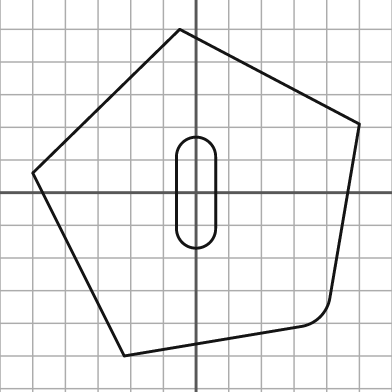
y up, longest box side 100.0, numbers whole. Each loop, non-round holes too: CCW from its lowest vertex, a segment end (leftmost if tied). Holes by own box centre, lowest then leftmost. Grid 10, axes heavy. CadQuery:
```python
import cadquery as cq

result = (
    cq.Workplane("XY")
    .moveTo(-22.0, -50.0)
    .lineTo(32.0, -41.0)
    .threePointArc((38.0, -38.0), (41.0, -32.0))
    .lineTo(50.0, 21.0)
    .lineTo(-5.0, 50.0)
    .lineTo(-50.0, 6.0)
    .close()
    .moveTo(-6.0, -11.0)
    .threePointArc((0.0, -17.0), (6.0, -11.0))
    .lineTo(6.0, 11.0)
    .threePointArc((0.0, 17.0), (-6.0, 11.0))
    .close()
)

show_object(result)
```